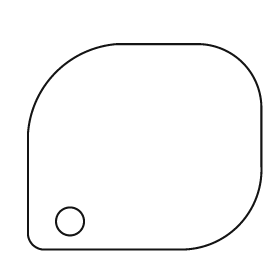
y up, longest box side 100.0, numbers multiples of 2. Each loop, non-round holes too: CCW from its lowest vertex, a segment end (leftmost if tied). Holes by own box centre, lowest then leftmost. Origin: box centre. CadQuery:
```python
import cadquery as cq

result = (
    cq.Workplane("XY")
    .moveTo(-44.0, -44.0)
    .lineTo(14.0, -44.0)
    .threePointArc((40.0, -34.0), (50.0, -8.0))
    .lineTo(50.0, 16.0)
    .threePointArc((42.0, 36.0), (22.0, 44.0))
    .lineTo(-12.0, 44.0)
    .threePointArc((-38.0, 32.0), (-50.0, 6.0))
    .lineTo(-50.0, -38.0)
    .threePointArc((-48.0, -42.0), (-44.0, -44.0))
    .close()
    .moveTo(-32.0, -32.0)
    .circle(6.0)
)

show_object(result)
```